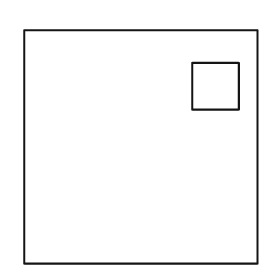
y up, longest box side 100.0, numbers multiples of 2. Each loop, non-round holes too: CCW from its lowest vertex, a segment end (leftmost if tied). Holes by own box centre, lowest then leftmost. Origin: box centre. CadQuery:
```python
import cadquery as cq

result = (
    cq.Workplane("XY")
    .moveTo(-50.0, -50.0)
    .lineTo(50.0, -50.0)
    .lineTo(50.0, 50.0)
    .lineTo(-50.0, 50.0)
    .close()
    .moveTo(22.0, 16.0)
    .lineTo(42.0, 16.0)
    .lineTo(42.0, 36.0)
    .lineTo(22.0, 36.0)
    .close()
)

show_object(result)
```